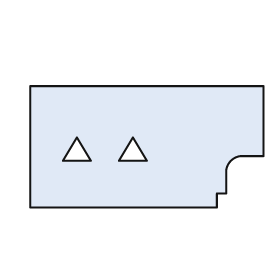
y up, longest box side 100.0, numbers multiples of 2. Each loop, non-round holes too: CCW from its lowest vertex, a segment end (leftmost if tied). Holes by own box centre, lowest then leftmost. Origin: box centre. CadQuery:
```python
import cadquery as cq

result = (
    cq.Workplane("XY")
    .moveTo(-50.0, -26.0)
    .lineTo(30.0, -26.0)
    .lineTo(30.0, -20.0)
    .lineTo(34.0, -20.0)
    .lineTo(34.0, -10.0)
    .threePointArc((36.0, -6.0), (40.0, -4.0))
    .lineTo(50.0, -4.0)
    .lineTo(50.0, 26.0)
    .lineTo(-50.0, 26.0)
    .close()
    .moveTo(-36.0, -6.0)
    .lineTo(-24.0, -6.0)
    .lineTo(-30.0, 4.0)
    .close()
    .moveTo(-12.0, -6.0)
    .lineTo(0.0, -6.0)
    .lineTo(-6.0, 4.0)
    .close()
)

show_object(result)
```